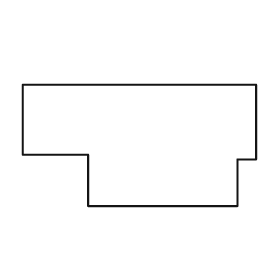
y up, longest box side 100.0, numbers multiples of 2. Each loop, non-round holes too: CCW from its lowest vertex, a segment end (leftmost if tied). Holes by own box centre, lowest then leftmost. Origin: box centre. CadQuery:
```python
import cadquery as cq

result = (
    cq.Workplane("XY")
    .moveTo(-22.0, -26.0)
    .lineTo(42.0, -26.0)
    .lineTo(42.0, -6.0)
    .lineTo(50.0, -6.0)
    .lineTo(50.0, 26.0)
    .lineTo(-50.0, 26.0)
    .lineTo(-50.0, -4.0)
    .lineTo(-22.0, -4.0)
    .close()
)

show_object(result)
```